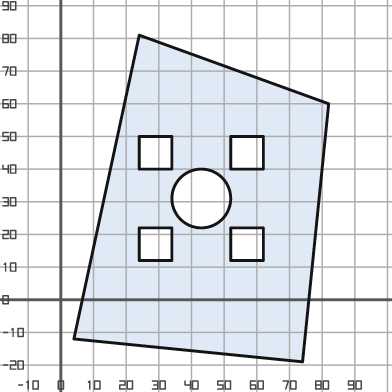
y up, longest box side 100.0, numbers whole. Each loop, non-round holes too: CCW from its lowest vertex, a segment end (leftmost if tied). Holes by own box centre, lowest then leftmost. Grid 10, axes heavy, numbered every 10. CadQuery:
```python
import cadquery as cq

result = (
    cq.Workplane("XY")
    .moveTo(74.0, -19.0)
    .lineTo(82.0, 60.0)
    .lineTo(24.0, 81.0)
    .lineTo(4.0, -12.0)
    .close()
    .moveTo(24.0, 12.0)
    .lineTo(34.0, 12.0)
    .lineTo(34.0, 22.0)
    .lineTo(24.0, 22.0)
    .close()
    .moveTo(52.0, 12.0)
    .lineTo(62.0, 12.0)
    .lineTo(62.0, 22.0)
    .lineTo(52.0, 22.0)
    .close()
    .moveTo(43.0, 31.0)
    .circle(9.0)
    .moveTo(24.0, 40.0)
    .lineTo(34.0, 40.0)
    .lineTo(34.0, 50.0)
    .lineTo(24.0, 50.0)
    .close()
    .moveTo(52.0, 40.0)
    .lineTo(62.0, 40.0)
    .lineTo(62.0, 50.0)
    .lineTo(52.0, 50.0)
    .close()
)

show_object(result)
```